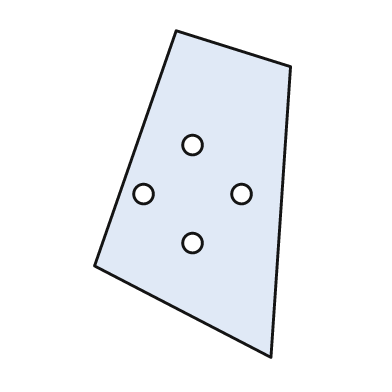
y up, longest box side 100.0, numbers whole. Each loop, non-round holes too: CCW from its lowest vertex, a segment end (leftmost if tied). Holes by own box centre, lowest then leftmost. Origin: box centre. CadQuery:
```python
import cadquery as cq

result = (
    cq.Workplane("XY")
    .moveTo(24.0, -50.0)
    .lineTo(30.0, 39.0)
    .lineTo(-5.0, 50.0)
    .lineTo(-30.0, -22.0)
    .close()
    .moveTo(0.0, -15.0)
    .circle(3.0)
    .moveTo(-15.0, 0.0)
    .circle(3.0)
    .moveTo(15.0, 0.0)
    .circle(3.0)
    .moveTo(0.0, 15.0)
    .circle(3.0)
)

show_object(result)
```